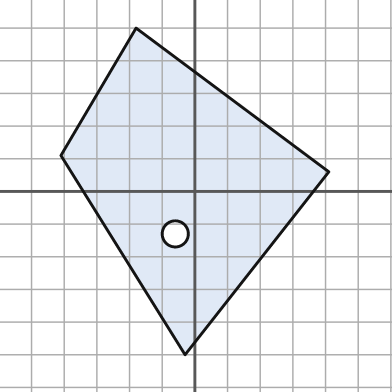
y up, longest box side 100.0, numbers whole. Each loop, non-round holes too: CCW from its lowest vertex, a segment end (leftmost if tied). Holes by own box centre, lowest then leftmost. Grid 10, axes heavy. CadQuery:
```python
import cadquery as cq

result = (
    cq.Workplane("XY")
    .moveTo(-3.0, -50.0)
    .lineTo(41.0, 6.0)
    .lineTo(-18.0, 50.0)
    .lineTo(-41.0, 11.0)
    .close()
    .moveTo(-6.0, -13.0)
    .circle(4.0)
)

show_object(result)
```